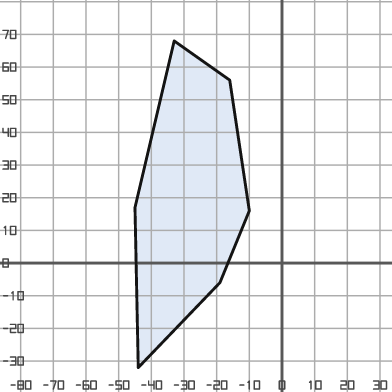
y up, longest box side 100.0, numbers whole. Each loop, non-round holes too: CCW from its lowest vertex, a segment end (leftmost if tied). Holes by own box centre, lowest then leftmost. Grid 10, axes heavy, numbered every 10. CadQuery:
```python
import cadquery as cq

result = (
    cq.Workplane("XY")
    .moveTo(-44.0, -32.0)
    .lineTo(-19.0, -6.0)
    .lineTo(-10.0, 16.0)
    .lineTo(-16.0, 56.0)
    .lineTo(-33.0, 68.0)
    .lineTo(-45.0, 17.0)
    .close()
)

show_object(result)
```